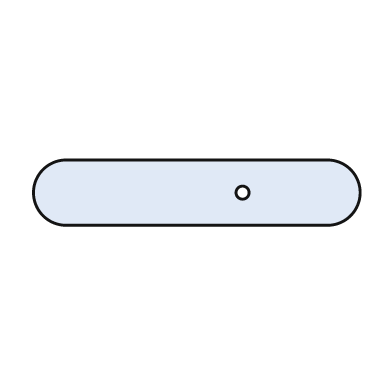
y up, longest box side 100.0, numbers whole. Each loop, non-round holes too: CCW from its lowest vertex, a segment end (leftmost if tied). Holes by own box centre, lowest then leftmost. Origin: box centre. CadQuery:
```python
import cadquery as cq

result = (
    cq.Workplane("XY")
    .moveTo(-40.0, -10.0)
    .lineTo(40.0, -10.0)
    .threePointArc((50.0, 0.0), (40.0, 10.0))
    .lineTo(-40.0, 10.0)
    .threePointArc((-50.0, 0.0), (-40.0, -10.0))
    .close()
    .moveTo(14.0, 0.0)
    .circle(2.0)
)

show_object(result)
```